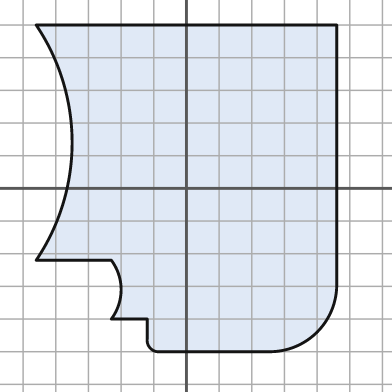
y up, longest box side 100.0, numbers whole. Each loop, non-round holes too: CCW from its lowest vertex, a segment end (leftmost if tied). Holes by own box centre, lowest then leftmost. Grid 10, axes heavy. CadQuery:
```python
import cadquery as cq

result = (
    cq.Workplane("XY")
    .moveTo(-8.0, -50.0)
    .lineTo(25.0, -50.0)
    .threePointArc((40.0, -44.0), (46.0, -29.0))
    .lineTo(46.0, 50.0)
    .lineTo(-46.0, 50.0)
    .threePointArc((-35.0, 14.0), (-46.0, -22.0))
    .lineTo(-23.0, -22.0)
    .threePointArc((-20.0, -31.0), (-23.0, -40.0))
    .lineTo(-12.0, -40.0)
    .lineTo(-12.0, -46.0)
    .threePointArc((-11.0, -49.0), (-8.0, -50.0))
    .close()
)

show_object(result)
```